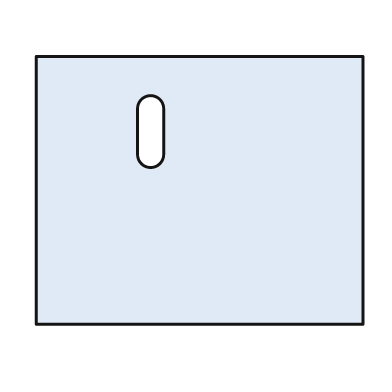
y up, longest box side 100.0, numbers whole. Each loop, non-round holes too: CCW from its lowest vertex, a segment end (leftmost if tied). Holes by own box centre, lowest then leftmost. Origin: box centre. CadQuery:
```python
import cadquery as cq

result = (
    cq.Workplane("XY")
    .moveTo(-50.0, -41.0)
    .lineTo(50.0, -41.0)
    .lineTo(50.0, 41.0)
    .lineTo(-50.0, 41.0)
    .close()
    .moveTo(-19.0, 11.0)
    .threePointArc((-15.0, 7.0), (-11.0, 11.0))
    .lineTo(-11.0, 25.0)
    .threePointArc((-15.0, 29.0), (-19.0, 25.0))
    .close()
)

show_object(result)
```